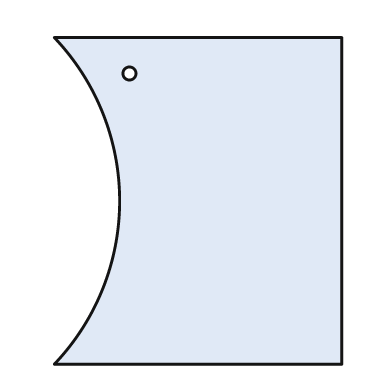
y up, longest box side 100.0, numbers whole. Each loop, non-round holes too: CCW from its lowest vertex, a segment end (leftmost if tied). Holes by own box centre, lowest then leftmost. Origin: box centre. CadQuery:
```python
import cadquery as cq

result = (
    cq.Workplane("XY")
    .moveTo(-44.0, -50.0)
    .lineTo(44.0, -50.0)
    .lineTo(44.0, 50.0)
    .lineTo(-44.0, 50.0)
    .threePointArc((-24.0, 0.0), (-44.0, -50.0))
    .close()
    .moveTo(-21.0, 39.0)
    .circle(2.0)
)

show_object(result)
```